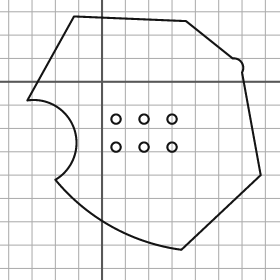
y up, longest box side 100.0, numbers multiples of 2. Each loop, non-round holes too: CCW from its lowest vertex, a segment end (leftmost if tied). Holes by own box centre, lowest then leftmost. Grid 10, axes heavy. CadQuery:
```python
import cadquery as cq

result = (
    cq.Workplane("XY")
    .moveTo(34.0, -72.0)
    .lineTo(68.0, -40.0)
    .lineTo(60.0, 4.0)
    .threePointArc((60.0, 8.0), (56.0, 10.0))
    .lineTo(36.0, 26.0)
    .lineTo(-12.0, 28.0)
    .lineTo(-32.0, -8.0)
    .threePointArc((-12.0, -20.0), (-20.0, -42.0))
    .threePointArc((4.0, -62.0), (34.0, -72.0))
    .close()
    .moveTo(6.0, -28.0)
    .circle(2.0)
    .moveTo(18.0, -28.0)
    .circle(2.0)
    .moveTo(30.0, -28.0)
    .circle(2.0)
    .moveTo(6.0, -16.0)
    .circle(2.0)
    .moveTo(18.0, -16.0)
    .circle(2.0)
    .moveTo(30.0, -16.0)
    .circle(2.0)
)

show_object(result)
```